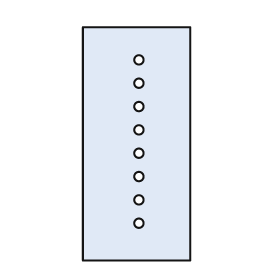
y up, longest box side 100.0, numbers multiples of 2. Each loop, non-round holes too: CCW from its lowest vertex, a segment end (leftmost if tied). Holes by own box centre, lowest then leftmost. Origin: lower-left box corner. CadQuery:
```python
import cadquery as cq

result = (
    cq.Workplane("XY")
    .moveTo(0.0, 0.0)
    .lineTo(46.0, 0.0)
    .lineTo(46.0, 100.0)
    .lineTo(0.0, 100.0)
    .close()
    .moveTo(24.0, 16.0)
    .circle(2.0)
    .moveTo(24.0, 26.0)
    .circle(2.0)
    .moveTo(24.0, 36.0)
    .circle(2.0)
    .moveTo(24.0, 46.0)
    .circle(2.0)
    .moveTo(24.0, 56.0)
    .circle(2.0)
    .moveTo(24.0, 66.0)
    .circle(2.0)
    .moveTo(24.0, 76.0)
    .circle(2.0)
    .moveTo(24.0, 86.0)
    .circle(2.0)
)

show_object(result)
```